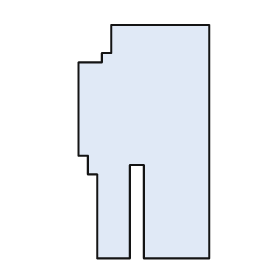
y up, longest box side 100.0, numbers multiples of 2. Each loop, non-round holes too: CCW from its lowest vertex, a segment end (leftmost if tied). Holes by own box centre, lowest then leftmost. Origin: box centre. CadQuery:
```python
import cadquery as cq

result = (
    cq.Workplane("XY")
    .moveTo(-20.0, -50.0)
    .lineTo(-6.0, -50.0)
    .lineTo(-6.0, -10.0)
    .lineTo(0.0, -10.0)
    .lineTo(0.0, -50.0)
    .lineTo(28.0, -50.0)
    .lineTo(28.0, 50.0)
    .lineTo(-14.0, 50.0)
    .lineTo(-14.0, 38.0)
    .lineTo(-18.0, 38.0)
    .lineTo(-18.0, 34.0)
    .lineTo(-28.0, 34.0)
    .lineTo(-28.0, -6.0)
    .lineTo(-24.0, -6.0)
    .lineTo(-24.0, -14.0)
    .lineTo(-20.0, -14.0)
    .close()
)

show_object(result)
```